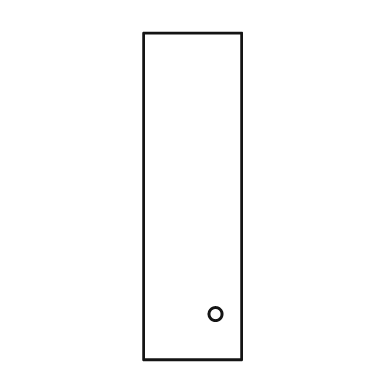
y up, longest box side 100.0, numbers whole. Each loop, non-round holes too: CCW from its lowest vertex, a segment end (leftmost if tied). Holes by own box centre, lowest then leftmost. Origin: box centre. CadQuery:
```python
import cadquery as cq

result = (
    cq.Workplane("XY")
    .moveTo(-15.0, -50.0)
    .lineTo(15.0, -50.0)
    .lineTo(15.0, 50.0)
    .lineTo(-15.0, 50.0)
    .close()
    .moveTo(7.0, -36.0)
    .circle(2.0)
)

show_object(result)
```